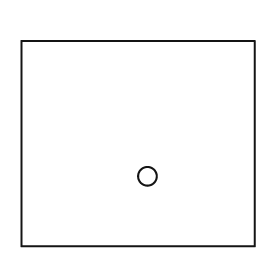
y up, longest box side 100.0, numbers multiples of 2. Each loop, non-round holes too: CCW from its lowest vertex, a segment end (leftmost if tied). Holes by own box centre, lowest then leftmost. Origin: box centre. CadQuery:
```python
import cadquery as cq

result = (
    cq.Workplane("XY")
    .moveTo(-50.0, -44.0)
    .lineTo(50.0, -44.0)
    .lineTo(50.0, 44.0)
    .lineTo(-50.0, 44.0)
    .close()
    .moveTo(4.0, -14.0)
    .circle(4.0)
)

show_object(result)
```